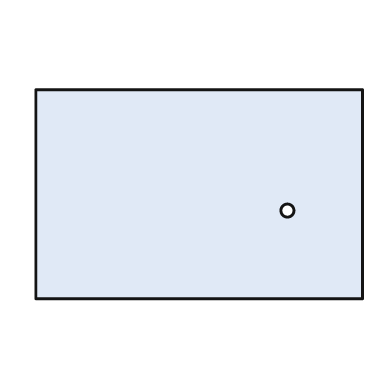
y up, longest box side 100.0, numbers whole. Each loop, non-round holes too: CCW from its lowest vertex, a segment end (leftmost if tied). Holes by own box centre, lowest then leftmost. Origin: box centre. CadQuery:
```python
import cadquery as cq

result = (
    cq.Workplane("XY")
    .moveTo(-50.0, -32.0)
    .lineTo(50.0, -32.0)
    .lineTo(50.0, 32.0)
    .lineTo(-50.0, 32.0)
    .close()
    .moveTo(27.0, -5.0)
    .circle(2.0)
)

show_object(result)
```